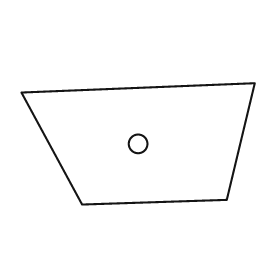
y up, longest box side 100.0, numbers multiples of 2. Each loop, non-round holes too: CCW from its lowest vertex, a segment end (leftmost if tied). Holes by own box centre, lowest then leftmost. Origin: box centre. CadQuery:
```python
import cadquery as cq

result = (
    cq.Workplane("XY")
    .moveTo(-24.0, -26.0)
    .lineTo(38.0, -24.0)
    .lineTo(50.0, 26.0)
    .lineTo(-50.0, 22.0)
    .close()
    .moveTo(0.0, 0.0)
    .circle(4.0)
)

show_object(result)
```